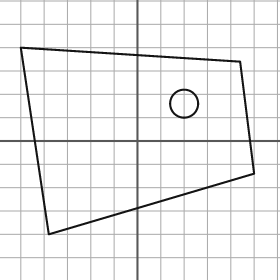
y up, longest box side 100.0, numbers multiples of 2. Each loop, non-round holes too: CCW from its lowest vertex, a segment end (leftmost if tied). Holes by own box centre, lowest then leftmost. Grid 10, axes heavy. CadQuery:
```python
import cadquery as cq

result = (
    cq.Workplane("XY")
    .moveTo(-38.0, -40.0)
    .lineTo(50.0, -14.0)
    .lineTo(44.0, 34.0)
    .lineTo(-50.0, 40.0)
    .close()
    .moveTo(20.0, 16.0)
    .circle(6.0)
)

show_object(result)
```